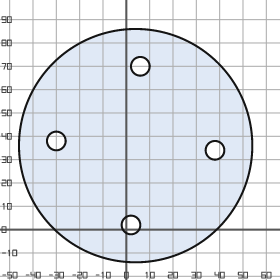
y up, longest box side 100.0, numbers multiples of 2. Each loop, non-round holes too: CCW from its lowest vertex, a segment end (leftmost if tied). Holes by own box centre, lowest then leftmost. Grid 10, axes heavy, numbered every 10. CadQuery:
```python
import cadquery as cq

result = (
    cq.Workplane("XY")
    .moveTo(4.0, 36.0)
    .circle(50.0)
    .moveTo(2.0, 2.0)
    .circle(4.0)
    .moveTo(38.0, 34.0)
    .circle(4.0)
    .moveTo(-30.0, 38.0)
    .circle(4.0)
    .moveTo(6.0, 70.0)
    .circle(4.0)
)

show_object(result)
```